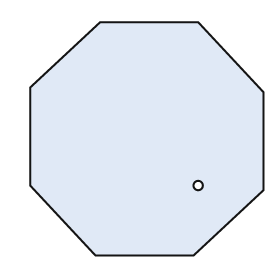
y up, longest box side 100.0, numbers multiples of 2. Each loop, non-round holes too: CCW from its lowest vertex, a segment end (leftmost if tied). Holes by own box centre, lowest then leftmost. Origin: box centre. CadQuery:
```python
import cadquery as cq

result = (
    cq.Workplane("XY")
    .moveTo(-22.0, -50.0)
    .lineTo(20.0, -50.0)
    .lineTo(50.0, -22.0)
    .lineTo(50.0, 20.0)
    .lineTo(22.0, 50.0)
    .lineTo(-20.0, 50.0)
    .lineTo(-50.0, 22.0)
    .lineTo(-50.0, -20.0)
    .close()
    .moveTo(22.0, -20.0)
    .circle(2.0)
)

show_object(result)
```